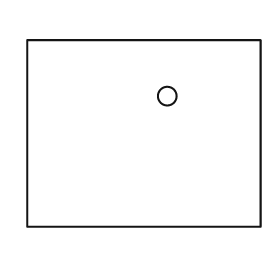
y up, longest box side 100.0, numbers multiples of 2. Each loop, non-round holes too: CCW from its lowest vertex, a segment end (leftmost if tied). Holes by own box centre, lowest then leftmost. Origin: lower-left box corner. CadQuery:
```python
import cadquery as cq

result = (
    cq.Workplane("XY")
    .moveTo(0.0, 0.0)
    .lineTo(100.0, 0.0)
    .lineTo(100.0, 80.0)
    .lineTo(0.0, 80.0)
    .close()
    .moveTo(60.0, 56.0)
    .circle(4.0)
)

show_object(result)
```